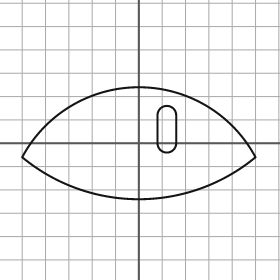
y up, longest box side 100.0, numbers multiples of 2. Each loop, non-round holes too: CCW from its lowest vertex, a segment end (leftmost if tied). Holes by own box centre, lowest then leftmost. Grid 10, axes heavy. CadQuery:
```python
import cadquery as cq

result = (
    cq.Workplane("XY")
    .moveTo(-50.0, -6.0)
    .threePointArc((0.0, -24.0), (50.0, -6.0))
    .threePointArc((0.0, 24.0), (-50.0, -6.0))
    .close()
    .moveTo(8.0, 0.0)
    .threePointArc((12.0, -4.0), (16.0, 0.0))
    .lineTo(16.0, 12.0)
    .threePointArc((12.0, 16.0), (8.0, 12.0))
    .close()
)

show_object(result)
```